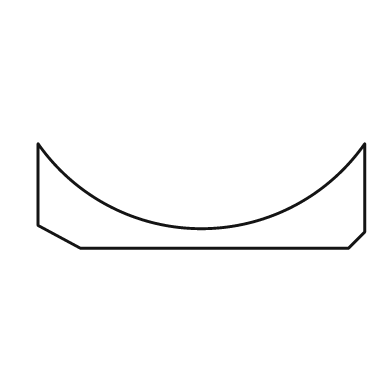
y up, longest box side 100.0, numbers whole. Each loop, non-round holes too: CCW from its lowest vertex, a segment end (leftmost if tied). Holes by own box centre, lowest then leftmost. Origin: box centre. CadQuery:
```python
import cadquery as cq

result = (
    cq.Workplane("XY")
    .moveTo(-37.0, -16.0)
    .lineTo(45.0, -16.0)
    .lineTo(50.0, -11.0)
    .lineTo(50.0, 16.0)
    .threePointArc((0.0, -10.0), (-50.0, 16.0))
    .lineTo(-50.0, -9.0)
    .close()
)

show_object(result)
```